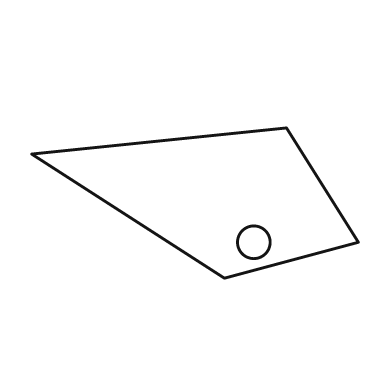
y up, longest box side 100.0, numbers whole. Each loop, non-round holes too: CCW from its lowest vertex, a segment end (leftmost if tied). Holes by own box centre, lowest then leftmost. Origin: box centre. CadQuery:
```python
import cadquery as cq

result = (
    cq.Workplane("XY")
    .moveTo(9.0, -23.0)
    .lineTo(50.0, -12.0)
    .lineTo(28.0, 23.0)
    .lineTo(-50.0, 15.0)
    .close()
    .moveTo(18.0, -12.0)
    .circle(5.0)
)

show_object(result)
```